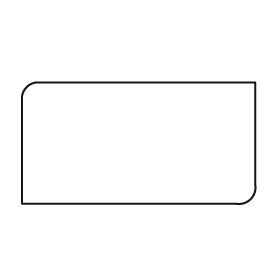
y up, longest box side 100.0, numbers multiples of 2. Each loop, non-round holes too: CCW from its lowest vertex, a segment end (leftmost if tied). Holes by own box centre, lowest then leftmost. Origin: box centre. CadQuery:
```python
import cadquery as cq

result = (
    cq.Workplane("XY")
    .moveTo(-50.0, -26.0)
    .lineTo(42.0, -26.0)
    .threePointArc((48.0, -24.0), (50.0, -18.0))
    .lineTo(50.0, 26.0)
    .lineTo(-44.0, 26.0)
    .threePointArc((-48.0, 24.0), (-50.0, 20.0))
    .close()
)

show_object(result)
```